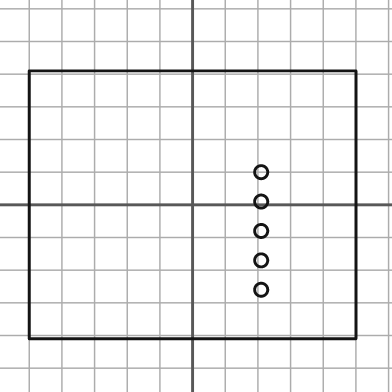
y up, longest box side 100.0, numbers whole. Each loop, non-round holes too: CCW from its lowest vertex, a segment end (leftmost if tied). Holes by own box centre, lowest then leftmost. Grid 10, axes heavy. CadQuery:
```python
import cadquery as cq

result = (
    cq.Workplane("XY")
    .moveTo(-50.0, -41.0)
    .lineTo(50.0, -41.0)
    .lineTo(50.0, 41.0)
    .lineTo(-50.0, 41.0)
    .close()
    .moveTo(21.0, -26.0)
    .circle(2.0)
    .moveTo(21.0, -17.0)
    .circle(2.0)
    .moveTo(21.0, -8.0)
    .circle(2.0)
    .moveTo(21.0, 1.0)
    .circle(2.0)
    .moveTo(21.0, 10.0)
    .circle(2.0)
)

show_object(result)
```